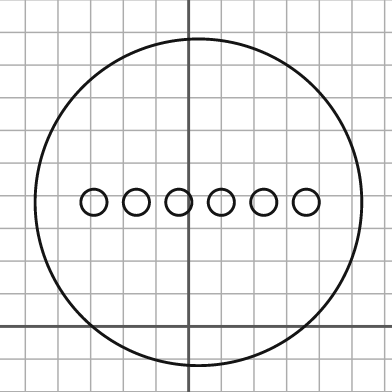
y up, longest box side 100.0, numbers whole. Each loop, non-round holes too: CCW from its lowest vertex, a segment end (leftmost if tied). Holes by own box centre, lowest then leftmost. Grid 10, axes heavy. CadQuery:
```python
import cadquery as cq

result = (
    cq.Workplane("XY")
    .moveTo(3.0, 38.0)
    .circle(50.0)
    .moveTo(-29.0, 38.0)
    .circle(4.0)
    .moveTo(-16.0, 38.0)
    .circle(4.0)
    .moveTo(-3.0, 38.0)
    .circle(4.0)
    .moveTo(10.0, 38.0)
    .circle(4.0)
    .moveTo(23.0, 38.0)
    .circle(4.0)
    .moveTo(36.0, 38.0)
    .circle(4.0)
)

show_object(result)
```